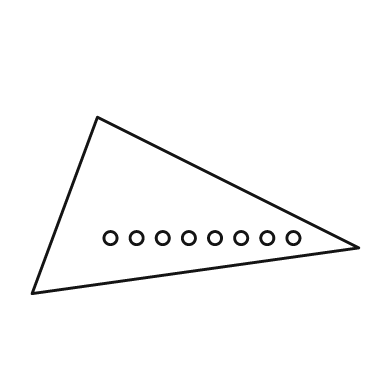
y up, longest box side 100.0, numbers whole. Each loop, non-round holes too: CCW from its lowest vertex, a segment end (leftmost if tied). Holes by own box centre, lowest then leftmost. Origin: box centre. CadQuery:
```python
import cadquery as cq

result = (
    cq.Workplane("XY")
    .moveTo(-50.0, -27.0)
    .lineTo(50.0, -13.0)
    .lineTo(-30.0, 27.0)
    .close()
    .moveTo(-26.0, -10.0)
    .circle(2.0)
    .moveTo(-18.0, -10.0)
    .circle(2.0)
    .moveTo(-10.0, -10.0)
    .circle(2.0)
    .moveTo(-2.0, -10.0)
    .circle(2.0)
    .moveTo(6.0, -10.0)
    .circle(2.0)
    .moveTo(14.0, -10.0)
    .circle(2.0)
    .moveTo(22.0, -10.0)
    .circle(2.0)
    .moveTo(30.0, -10.0)
    .circle(2.0)
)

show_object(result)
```